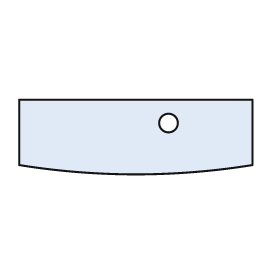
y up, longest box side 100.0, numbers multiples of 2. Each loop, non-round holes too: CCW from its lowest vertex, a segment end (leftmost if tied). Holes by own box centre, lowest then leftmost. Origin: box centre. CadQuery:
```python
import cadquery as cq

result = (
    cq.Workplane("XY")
    .moveTo(-50.0, -12.0)
    .threePointArc((0.0, -16.0), (50.0, -12.0))
    .lineTo(50.0, 16.0)
    .lineTo(-50.0, 16.0)
    .close()
    .moveTo(14.0, 6.0)
    .circle(4.0)
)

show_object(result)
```